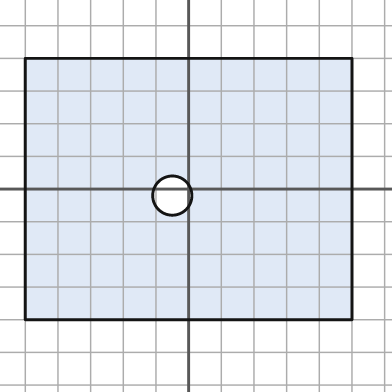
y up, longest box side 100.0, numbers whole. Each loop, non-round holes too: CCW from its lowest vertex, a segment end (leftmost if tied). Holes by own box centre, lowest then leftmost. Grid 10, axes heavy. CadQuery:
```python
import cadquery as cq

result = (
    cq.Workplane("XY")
    .moveTo(-50.0, -40.0)
    .lineTo(50.0, -40.0)
    .lineTo(50.0, 40.0)
    .lineTo(-50.0, 40.0)
    .close()
    .moveTo(-5.0, -2.0)
    .circle(6.0)
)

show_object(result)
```